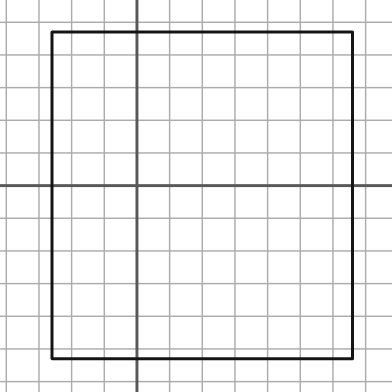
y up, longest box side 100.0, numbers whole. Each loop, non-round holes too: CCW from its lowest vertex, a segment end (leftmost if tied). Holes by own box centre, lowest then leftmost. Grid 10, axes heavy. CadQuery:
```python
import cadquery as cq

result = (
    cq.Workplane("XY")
    .moveTo(-26.0, -53.0)
    .lineTo(66.0, -53.0)
    .lineTo(66.0, 47.0)
    .lineTo(-26.0, 47.0)
    .close()
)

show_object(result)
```